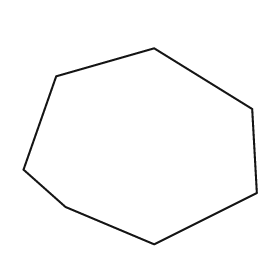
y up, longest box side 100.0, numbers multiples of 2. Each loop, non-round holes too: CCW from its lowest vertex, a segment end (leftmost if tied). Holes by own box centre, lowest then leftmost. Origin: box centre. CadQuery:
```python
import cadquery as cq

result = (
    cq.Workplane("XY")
    .moveTo(6.0, -42.0)
    .lineTo(50.0, -20.0)
    .lineTo(48.0, 16.0)
    .lineTo(6.0, 42.0)
    .lineTo(-36.0, 30.0)
    .lineTo(-50.0, -10.0)
    .lineTo(-32.0, -26.0)
    .close()
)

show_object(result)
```